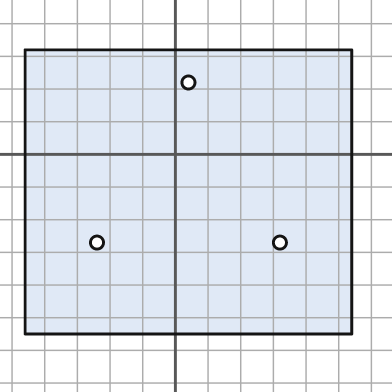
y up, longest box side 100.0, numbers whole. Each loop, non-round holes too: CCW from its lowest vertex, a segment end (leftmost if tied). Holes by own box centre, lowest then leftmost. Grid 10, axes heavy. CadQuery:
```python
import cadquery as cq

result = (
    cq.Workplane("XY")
    .moveTo(-46.0, -55.0)
    .lineTo(54.0, -55.0)
    .lineTo(54.0, 32.0)
    .lineTo(-46.0, 32.0)
    .close()
    .moveTo(-24.0, -27.0)
    .circle(2.0)
    .moveTo(32.0, -27.0)
    .circle(2.0)
    .moveTo(4.0, 22.0)
    .circle(2.0)
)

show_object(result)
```